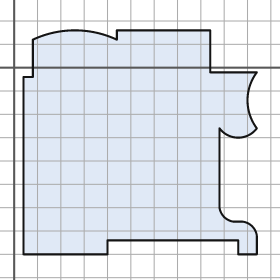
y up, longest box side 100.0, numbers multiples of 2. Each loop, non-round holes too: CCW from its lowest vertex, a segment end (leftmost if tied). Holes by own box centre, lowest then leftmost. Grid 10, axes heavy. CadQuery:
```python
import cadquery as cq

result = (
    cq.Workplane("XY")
    .moveTo(4.0, -80.0)
    .lineTo(40.0, -80.0)
    .lineTo(40.0, -74.0)
    .lineTo(96.0, -74.0)
    .lineTo(96.0, -80.0)
    .lineTo(104.0, -80.0)
    .lineTo(104.0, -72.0)
    .threePointArc((102.0, -68.0), (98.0, -66.0))
    .lineTo(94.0, -66.0)
    .threePointArc((90.0, -64.0), (88.0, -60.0))
    .lineTo(88.0, -26.0)
    .threePointArc((96.0, -30.0), (104.0, -26.0))
    .threePointArc((100.0, -14.0), (104.0, -2.0))
    .lineTo(84.0, -2.0)
    .lineTo(84.0, 16.0)
    .lineTo(44.0, 16.0)
    .lineTo(44.0, 12.0)
    .threePointArc((26.0, 16.0), (8.0, 12.0))
    .lineTo(8.0, -4.0)
    .lineTo(4.0, -4.0)
    .close()
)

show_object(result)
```